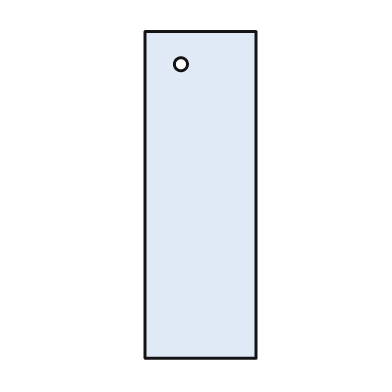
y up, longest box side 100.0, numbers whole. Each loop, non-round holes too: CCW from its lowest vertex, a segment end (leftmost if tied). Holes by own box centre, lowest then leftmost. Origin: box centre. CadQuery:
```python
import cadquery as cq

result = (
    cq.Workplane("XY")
    .moveTo(-17.0, -50.0)
    .lineTo(17.0, -50.0)
    .lineTo(17.0, 50.0)
    .lineTo(-17.0, 50.0)
    .close()
    .moveTo(-6.0, 40.0)
    .circle(2.0)
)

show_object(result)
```